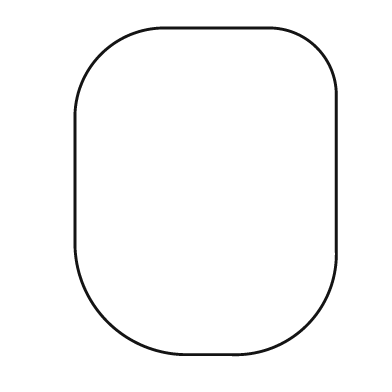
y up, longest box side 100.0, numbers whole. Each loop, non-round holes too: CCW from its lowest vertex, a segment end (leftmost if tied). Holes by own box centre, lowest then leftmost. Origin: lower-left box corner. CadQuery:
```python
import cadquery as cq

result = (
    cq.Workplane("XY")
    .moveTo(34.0, 0.0)
    .lineTo(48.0, 0.0)
    .threePointArc((71.0, 9.0), (80.0, 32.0))
    .lineTo(80.0, 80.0)
    .threePointArc((74.0, 94.0), (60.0, 100.0))
    .lineTo(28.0, 100.0)
    .threePointArc((8.0, 92.0), (0.0, 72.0))
    .lineTo(0.0, 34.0)
    .threePointArc((10.0, 10.0), (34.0, 0.0))
    .close()
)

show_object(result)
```